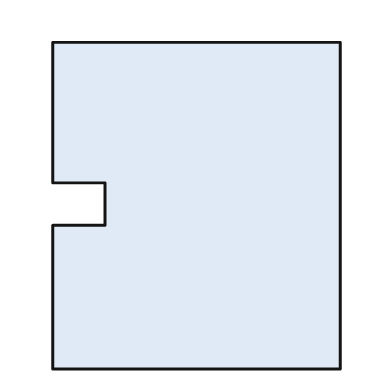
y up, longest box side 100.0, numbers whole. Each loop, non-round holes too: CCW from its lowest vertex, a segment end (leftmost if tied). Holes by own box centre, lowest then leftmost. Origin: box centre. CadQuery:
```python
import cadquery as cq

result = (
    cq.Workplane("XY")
    .moveTo(-44.0, -50.0)
    .lineTo(44.0, -50.0)
    .lineTo(44.0, 50.0)
    .lineTo(-44.0, 50.0)
    .lineTo(-44.0, 7.0)
    .lineTo(-28.0, 7.0)
    .lineTo(-28.0, -6.0)
    .lineTo(-44.0, -6.0)
    .close()
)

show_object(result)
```